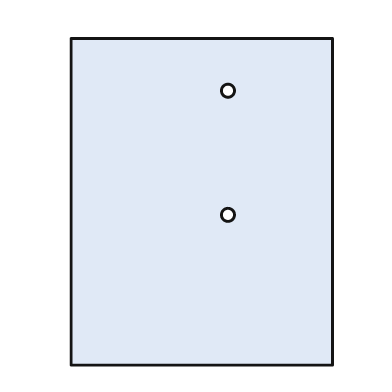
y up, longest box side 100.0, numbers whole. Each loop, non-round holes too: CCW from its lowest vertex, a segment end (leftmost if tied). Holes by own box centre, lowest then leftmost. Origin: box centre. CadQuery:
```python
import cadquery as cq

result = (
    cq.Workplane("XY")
    .moveTo(-40.0, -50.0)
    .lineTo(40.0, -50.0)
    .lineTo(40.0, 50.0)
    .lineTo(-40.0, 50.0)
    .close()
    .moveTo(8.0, -4.0)
    .circle(2.0)
    .moveTo(8.0, 34.0)
    .circle(2.0)
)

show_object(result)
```